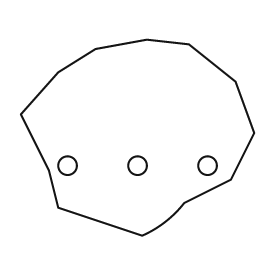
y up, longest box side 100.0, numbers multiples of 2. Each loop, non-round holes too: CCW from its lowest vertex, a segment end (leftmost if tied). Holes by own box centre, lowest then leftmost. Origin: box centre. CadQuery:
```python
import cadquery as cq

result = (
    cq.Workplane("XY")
    .moveTo(2.0, -42.0)
    .threePointArc((12.0, -36.0), (20.0, -28.0))
    .lineTo(40.0, -18.0)
    .lineTo(50.0, 2.0)
    .lineTo(42.0, 24.0)
    .lineTo(22.0, 40.0)
    .lineTo(4.0, 42.0)
    .lineTo(-18.0, 38.0)
    .lineTo(-34.0, 28.0)
    .lineTo(-50.0, 10.0)
    .lineTo(-38.0, -14.0)
    .lineTo(-34.0, -30.0)
    .close()
    .moveTo(-30.0, -12.0)
    .circle(4.0)
    .moveTo(0.0, -12.0)
    .circle(4.0)
    .moveTo(30.0, -12.0)
    .circle(4.0)
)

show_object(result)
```